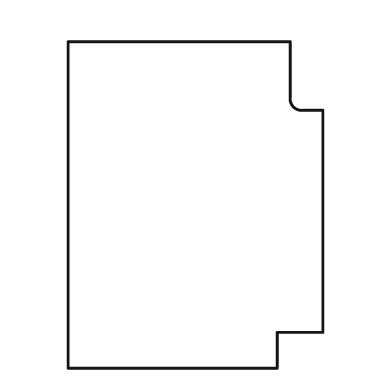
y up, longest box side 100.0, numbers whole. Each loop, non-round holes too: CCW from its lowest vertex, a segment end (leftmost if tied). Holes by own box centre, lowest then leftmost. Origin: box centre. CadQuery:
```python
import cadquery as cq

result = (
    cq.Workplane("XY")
    .moveTo(-39.0, -50.0)
    .lineTo(25.0, -50.0)
    .lineTo(25.0, -39.0)
    .lineTo(39.0, -39.0)
    .lineTo(39.0, 29.0)
    .lineTo(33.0, 29.0)
    .threePointArc((30.0, 30.0), (29.0, 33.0))
    .lineTo(29.0, 50.0)
    .lineTo(-39.0, 50.0)
    .close()
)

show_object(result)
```